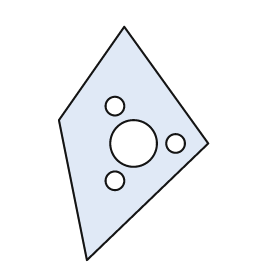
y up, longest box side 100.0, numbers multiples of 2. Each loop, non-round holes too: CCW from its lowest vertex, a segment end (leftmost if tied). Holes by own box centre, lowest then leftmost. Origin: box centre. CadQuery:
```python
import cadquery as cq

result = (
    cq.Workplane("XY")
    .moveTo(-20.0, -50.0)
    .lineTo(32.0, 0.0)
    .lineTo(-4.0, 50.0)
    .lineTo(-32.0, 10.0)
    .close()
    .moveTo(-8.0, -16.0)
    .circle(4.0)
    .moveTo(0.0, 0.0)
    .circle(10.0)
    .moveTo(18.0, 0.0)
    .circle(4.0)
    .moveTo(-8.0, 16.0)
    .circle(4.0)
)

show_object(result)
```